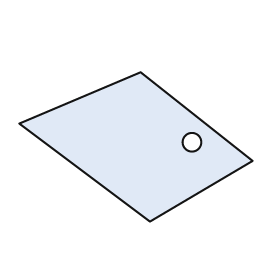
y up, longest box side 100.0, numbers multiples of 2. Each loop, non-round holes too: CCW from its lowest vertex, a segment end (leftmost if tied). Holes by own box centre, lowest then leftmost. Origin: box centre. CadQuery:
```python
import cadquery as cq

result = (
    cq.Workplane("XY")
    .moveTo(6.0, -32.0)
    .lineTo(50.0, -6.0)
    .lineTo(2.0, 32.0)
    .lineTo(-50.0, 10.0)
    .close()
    .moveTo(24.0, 2.0)
    .circle(4.0)
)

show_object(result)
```